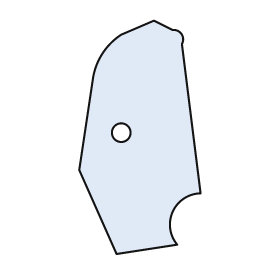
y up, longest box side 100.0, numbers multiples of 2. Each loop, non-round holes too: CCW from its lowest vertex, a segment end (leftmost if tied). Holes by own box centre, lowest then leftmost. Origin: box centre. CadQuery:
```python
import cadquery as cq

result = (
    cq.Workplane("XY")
    .moveTo(-10.0, -50.0)
    .lineTo(16.0, -46.0)
    .threePointArc((14.0, -32.0), (26.0, -24.0))
    .lineTo(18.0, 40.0)
    .threePointArc((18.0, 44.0), (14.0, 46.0))
    .lineTo(6.0, 50.0)
    .lineTo(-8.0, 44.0)
    .threePointArc((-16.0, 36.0), (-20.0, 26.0))
    .lineTo(-26.0, -14.0)
    .close()
    .moveTo(-8.0, 2.0)
    .circle(4.0)
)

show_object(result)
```